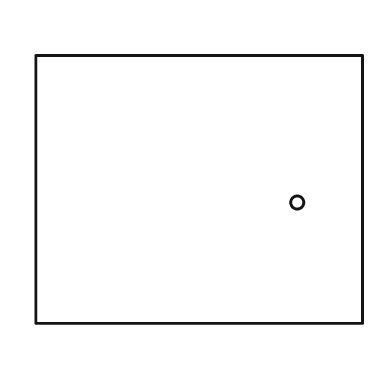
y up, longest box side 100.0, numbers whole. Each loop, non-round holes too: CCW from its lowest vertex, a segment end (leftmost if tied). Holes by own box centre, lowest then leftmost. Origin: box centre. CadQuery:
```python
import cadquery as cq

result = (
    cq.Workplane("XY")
    .moveTo(-50.0, -41.0)
    .lineTo(50.0, -41.0)
    .lineTo(50.0, 41.0)
    .lineTo(-50.0, 41.0)
    .close()
    .moveTo(30.0, -4.0)
    .circle(2.0)
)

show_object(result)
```